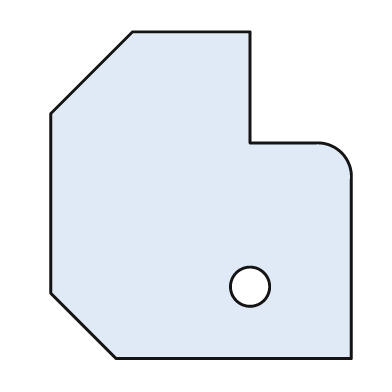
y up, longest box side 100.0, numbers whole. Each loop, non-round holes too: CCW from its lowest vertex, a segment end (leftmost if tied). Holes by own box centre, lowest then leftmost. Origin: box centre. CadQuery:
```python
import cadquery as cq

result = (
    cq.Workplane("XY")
    .moveTo(-26.0, -50.0)
    .lineTo(46.0, -50.0)
    .lineTo(46.0, 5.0)
    .threePointArc((43.0, 13.0), (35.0, 16.0))
    .lineTo(15.0, 16.0)
    .lineTo(15.0, 50.0)
    .lineTo(-21.0, 50.0)
    .lineTo(-46.0, 25.0)
    .lineTo(-46.0, -30.0)
    .close()
    .moveTo(15.0, -28.0)
    .circle(6.0)
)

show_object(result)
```